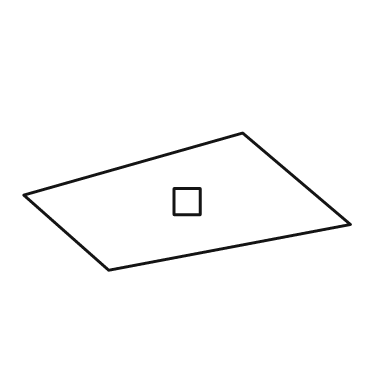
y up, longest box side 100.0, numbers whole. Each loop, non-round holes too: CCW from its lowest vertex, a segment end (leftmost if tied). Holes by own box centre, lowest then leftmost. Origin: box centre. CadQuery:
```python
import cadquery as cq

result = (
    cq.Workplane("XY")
    .moveTo(-24.0, -21.0)
    .lineTo(50.0, -7.0)
    .lineTo(17.0, 21.0)
    .lineTo(-50.0, 2.0)
    .close()
    .moveTo(-4.0, -4.0)
    .lineTo(4.0, -4.0)
    .lineTo(4.0, 4.0)
    .lineTo(-4.0, 4.0)
    .close()
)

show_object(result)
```